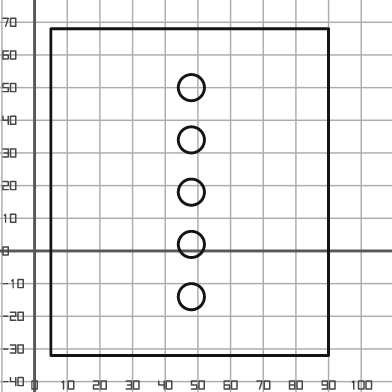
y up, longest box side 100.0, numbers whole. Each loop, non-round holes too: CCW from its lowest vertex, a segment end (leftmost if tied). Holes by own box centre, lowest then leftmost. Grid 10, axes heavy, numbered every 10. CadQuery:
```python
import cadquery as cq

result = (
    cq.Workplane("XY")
    .moveTo(5.0, -32.0)
    .lineTo(90.0, -32.0)
    .lineTo(90.0, 68.0)
    .lineTo(5.0, 68.0)
    .close()
    .moveTo(48.0, -14.0)
    .circle(4.0)
    .moveTo(48.0, 2.0)
    .circle(4.0)
    .moveTo(48.0, 18.0)
    .circle(4.0)
    .moveTo(48.0, 34.0)
    .circle(4.0)
    .moveTo(48.0, 50.0)
    .circle(4.0)
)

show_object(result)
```